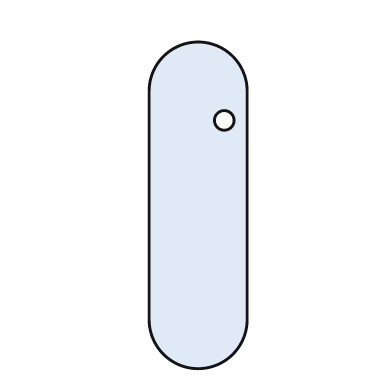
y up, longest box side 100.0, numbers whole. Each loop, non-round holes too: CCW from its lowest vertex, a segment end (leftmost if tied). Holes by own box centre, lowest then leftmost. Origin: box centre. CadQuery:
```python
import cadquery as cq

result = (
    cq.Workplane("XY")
    .moveTo(-15.0, -35.0)
    .threePointArc((0.0, -50.0), (15.0, -35.0))
    .lineTo(15.0, 35.0)
    .threePointArc((0.0, 50.0), (-15.0, 35.0))
    .close()
    .moveTo(8.0, 26.0)
    .circle(3.0)
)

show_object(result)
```